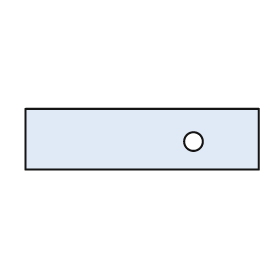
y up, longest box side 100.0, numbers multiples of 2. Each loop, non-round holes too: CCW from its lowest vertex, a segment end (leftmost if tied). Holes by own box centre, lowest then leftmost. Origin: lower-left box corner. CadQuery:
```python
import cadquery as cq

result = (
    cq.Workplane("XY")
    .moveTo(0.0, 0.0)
    .lineTo(100.0, 0.0)
    .lineTo(100.0, 26.0)
    .lineTo(0.0, 26.0)
    .close()
    .moveTo(72.0, 12.0)
    .circle(4.0)
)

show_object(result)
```